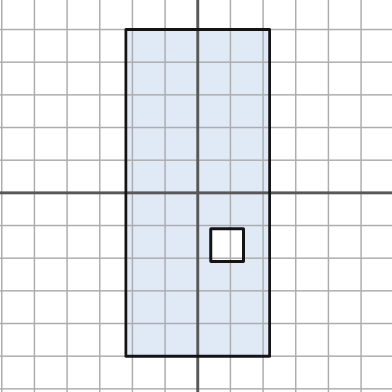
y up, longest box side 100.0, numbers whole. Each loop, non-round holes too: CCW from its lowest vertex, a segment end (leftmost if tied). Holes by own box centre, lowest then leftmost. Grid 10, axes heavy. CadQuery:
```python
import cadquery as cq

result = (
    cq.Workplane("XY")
    .moveTo(-22.0, -50.0)
    .lineTo(22.0, -50.0)
    .lineTo(22.0, 50.0)
    .lineTo(-22.0, 50.0)
    .close()
    .moveTo(4.0, -21.0)
    .lineTo(14.0, -21.0)
    .lineTo(14.0, -11.0)
    .lineTo(4.0, -11.0)
    .close()
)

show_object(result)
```